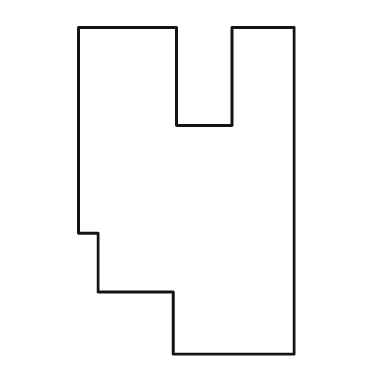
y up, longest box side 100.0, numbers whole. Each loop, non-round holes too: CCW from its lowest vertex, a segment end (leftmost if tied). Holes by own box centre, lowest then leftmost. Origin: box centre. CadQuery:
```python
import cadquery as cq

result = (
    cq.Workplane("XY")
    .moveTo(-4.0, -50.0)
    .lineTo(33.0, -50.0)
    .lineTo(33.0, 50.0)
    .lineTo(14.0, 50.0)
    .lineTo(14.0, 20.0)
    .lineTo(-3.0, 20.0)
    .lineTo(-3.0, 50.0)
    .lineTo(-33.0, 50.0)
    .lineTo(-33.0, -13.0)
    .lineTo(-27.0, -13.0)
    .lineTo(-27.0, -31.0)
    .lineTo(-4.0, -31.0)
    .close()
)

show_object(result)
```